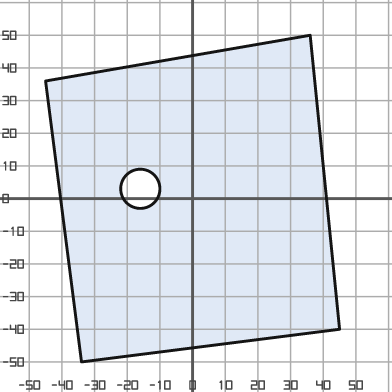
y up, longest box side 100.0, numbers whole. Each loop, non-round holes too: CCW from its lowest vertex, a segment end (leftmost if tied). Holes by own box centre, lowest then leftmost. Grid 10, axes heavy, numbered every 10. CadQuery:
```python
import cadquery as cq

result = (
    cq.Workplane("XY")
    .moveTo(-34.0, -50.0)
    .lineTo(45.0, -40.0)
    .lineTo(36.0, 50.0)
    .lineTo(-45.0, 36.0)
    .close()
    .moveTo(-16.0, 3.0)
    .circle(6.0)
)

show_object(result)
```